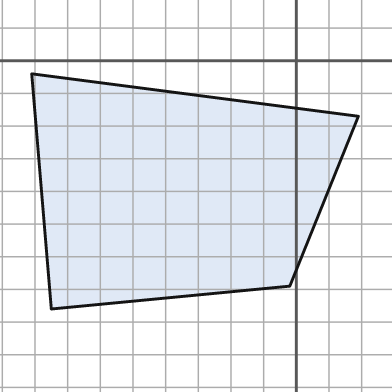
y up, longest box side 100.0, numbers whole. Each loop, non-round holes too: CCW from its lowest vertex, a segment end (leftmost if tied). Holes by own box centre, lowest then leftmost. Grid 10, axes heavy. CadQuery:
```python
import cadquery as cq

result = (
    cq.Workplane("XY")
    .moveTo(-75.0, -76.0)
    .lineTo(-2.0, -69.0)
    .lineTo(19.0, -17.0)
    .lineTo(-81.0, -4.0)
    .close()
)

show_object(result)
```